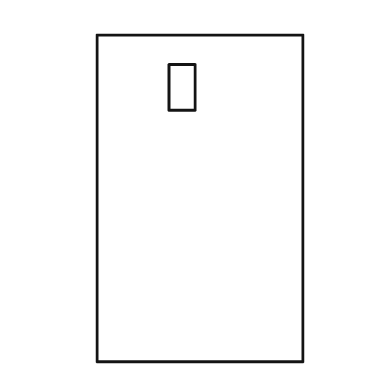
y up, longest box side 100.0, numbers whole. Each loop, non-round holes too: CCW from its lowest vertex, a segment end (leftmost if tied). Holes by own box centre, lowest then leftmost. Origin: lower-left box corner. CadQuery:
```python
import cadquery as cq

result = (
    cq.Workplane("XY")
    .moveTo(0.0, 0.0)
    .lineTo(63.0, 0.0)
    .lineTo(63.0, 100.0)
    .lineTo(0.0, 100.0)
    .close()
    .moveTo(22.0, 77.0)
    .lineTo(30.0, 77.0)
    .lineTo(30.0, 91.0)
    .lineTo(22.0, 91.0)
    .close()
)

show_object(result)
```